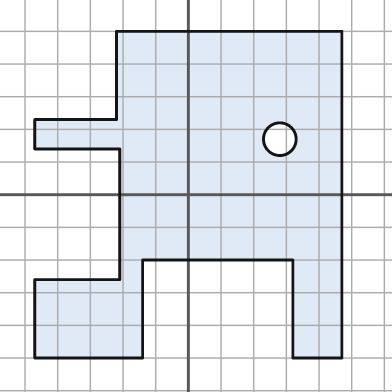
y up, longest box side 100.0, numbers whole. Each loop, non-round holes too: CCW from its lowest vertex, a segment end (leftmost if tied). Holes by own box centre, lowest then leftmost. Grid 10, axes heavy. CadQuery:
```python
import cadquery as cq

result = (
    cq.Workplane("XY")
    .moveTo(-47.0, -50.0)
    .lineTo(-14.0, -50.0)
    .lineTo(-14.0, -20.0)
    .lineTo(32.0, -20.0)
    .lineTo(32.0, -50.0)
    .lineTo(47.0, -50.0)
    .lineTo(47.0, 50.0)
    .lineTo(-22.0, 50.0)
    .lineTo(-22.0, 23.0)
    .lineTo(-47.0, 23.0)
    .lineTo(-47.0, 14.0)
    .lineTo(-21.0, 14.0)
    .lineTo(-21.0, -26.0)
    .lineTo(-47.0, -26.0)
    .close()
    .moveTo(28.0, 17.0)
    .circle(5.0)
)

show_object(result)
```